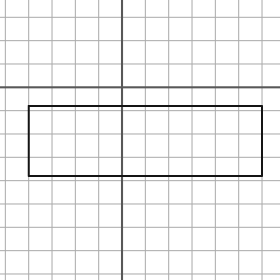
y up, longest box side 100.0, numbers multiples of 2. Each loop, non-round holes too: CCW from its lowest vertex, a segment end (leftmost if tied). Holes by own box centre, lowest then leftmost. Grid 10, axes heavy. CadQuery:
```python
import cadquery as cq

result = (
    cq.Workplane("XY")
    .moveTo(-40.0, -38.0)
    .lineTo(60.0, -38.0)
    .lineTo(60.0, -8.0)
    .lineTo(-40.0, -8.0)
    .close()
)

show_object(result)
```